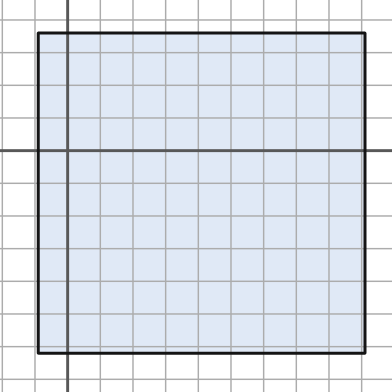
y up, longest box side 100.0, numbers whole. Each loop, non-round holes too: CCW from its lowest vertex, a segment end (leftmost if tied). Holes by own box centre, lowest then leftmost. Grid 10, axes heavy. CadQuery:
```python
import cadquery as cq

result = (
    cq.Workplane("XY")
    .moveTo(-9.0, -62.0)
    .lineTo(91.0, -62.0)
    .lineTo(91.0, 36.0)
    .lineTo(-9.0, 36.0)
    .close()
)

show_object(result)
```